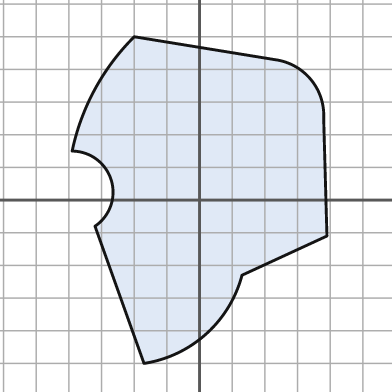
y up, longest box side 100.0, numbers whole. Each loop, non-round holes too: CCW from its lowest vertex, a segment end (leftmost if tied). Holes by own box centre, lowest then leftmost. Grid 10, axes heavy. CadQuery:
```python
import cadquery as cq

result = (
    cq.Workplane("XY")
    .moveTo(-17.0, -50.0)
    .threePointArc((2.0, -41.0), (13.0, -23.0))
    .lineTo(39.0, -11.0)
    .lineTo(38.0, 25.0)
    .threePointArc((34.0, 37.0), (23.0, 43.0))
    .lineTo(-20.0, 50.0)
    .threePointArc((-32.0, 34.0), (-39.0, 15.0))
    .threePointArc((-27.0, 6.0), (-32.0, -8.0))
    .close()
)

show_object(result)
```